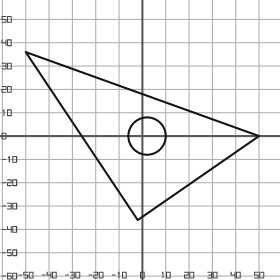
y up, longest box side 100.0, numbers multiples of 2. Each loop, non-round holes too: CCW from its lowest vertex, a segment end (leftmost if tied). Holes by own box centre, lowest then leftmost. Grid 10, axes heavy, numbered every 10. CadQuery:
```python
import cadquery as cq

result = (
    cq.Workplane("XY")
    .moveTo(-2.0, -36.0)
    .lineTo(50.0, 0.0)
    .lineTo(-50.0, 36.0)
    .close()
    .moveTo(2.0, 0.0)
    .circle(8.0)
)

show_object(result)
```